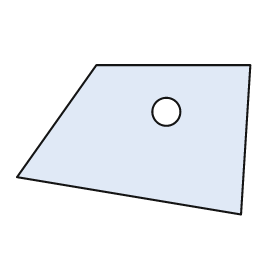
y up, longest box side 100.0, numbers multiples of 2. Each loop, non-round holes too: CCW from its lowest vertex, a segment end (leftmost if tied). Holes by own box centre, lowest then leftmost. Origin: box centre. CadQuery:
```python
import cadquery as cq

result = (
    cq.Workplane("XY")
    .moveTo(46.0, -32.0)
    .lineTo(50.0, 32.0)
    .lineTo(-16.0, 32.0)
    .lineTo(-50.0, -16.0)
    .close()
    .moveTo(14.0, 12.0)
    .circle(6.0)
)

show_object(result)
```